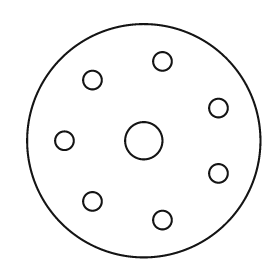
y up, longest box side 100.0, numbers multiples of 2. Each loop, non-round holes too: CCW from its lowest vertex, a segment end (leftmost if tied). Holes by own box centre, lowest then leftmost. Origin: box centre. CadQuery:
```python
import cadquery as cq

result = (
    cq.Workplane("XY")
    .moveTo(0.0, 0.0)
    .circle(50.0)
    .moveTo(8.0, -34.0)
    .circle(4.0)
    .moveTo(-22.0, -26.0)
    .circle(4.0)
    .moveTo(32.0, -14.0)
    .circle(4.0)
    .moveTo(-34.0, 0.0)
    .circle(4.0)
    .moveTo(0.0, 0.0)
    .circle(8.0)
    .moveTo(32.0, 14.0)
    .circle(4.0)
    .moveTo(-22.0, 26.0)
    .circle(4.0)
    .moveTo(8.0, 34.0)
    .circle(4.0)
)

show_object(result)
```